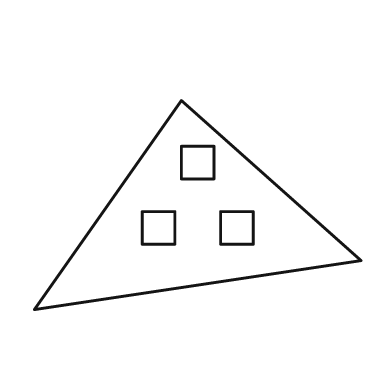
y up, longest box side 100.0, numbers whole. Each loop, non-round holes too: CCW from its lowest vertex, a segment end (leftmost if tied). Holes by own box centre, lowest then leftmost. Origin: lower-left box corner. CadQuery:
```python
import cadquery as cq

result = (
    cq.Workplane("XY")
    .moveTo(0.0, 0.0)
    .lineTo(100.0, 15.0)
    .lineTo(45.0, 64.0)
    .close()
    .moveTo(33.0, 20.0)
    .lineTo(43.0, 20.0)
    .lineTo(43.0, 30.0)
    .lineTo(33.0, 30.0)
    .close()
    .moveTo(57.0, 20.0)
    .lineTo(67.0, 20.0)
    .lineTo(67.0, 30.0)
    .lineTo(57.0, 30.0)
    .close()
    .moveTo(45.0, 40.0)
    .lineTo(55.0, 40.0)
    .lineTo(55.0, 50.0)
    .lineTo(45.0, 50.0)
    .close()
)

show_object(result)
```